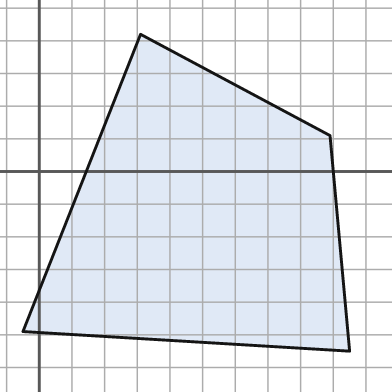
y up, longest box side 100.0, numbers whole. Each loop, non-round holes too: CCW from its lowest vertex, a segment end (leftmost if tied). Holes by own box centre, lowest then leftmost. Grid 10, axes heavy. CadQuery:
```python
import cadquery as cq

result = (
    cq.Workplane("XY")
    .moveTo(95.0, -55.0)
    .lineTo(89.0, 11.0)
    .lineTo(31.0, 42.0)
    .lineTo(-5.0, -49.0)
    .close()
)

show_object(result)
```